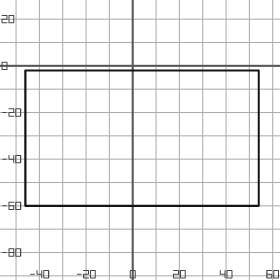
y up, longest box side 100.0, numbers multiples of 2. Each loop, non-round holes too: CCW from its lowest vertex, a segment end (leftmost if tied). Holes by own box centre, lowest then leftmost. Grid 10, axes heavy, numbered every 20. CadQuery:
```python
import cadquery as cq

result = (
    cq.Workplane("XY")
    .moveTo(-46.0, -60.0)
    .lineTo(54.0, -60.0)
    .lineTo(54.0, -2.0)
    .lineTo(-46.0, -2.0)
    .close()
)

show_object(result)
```